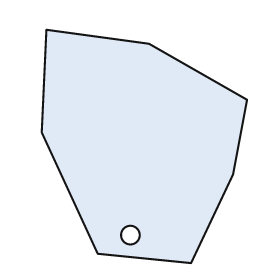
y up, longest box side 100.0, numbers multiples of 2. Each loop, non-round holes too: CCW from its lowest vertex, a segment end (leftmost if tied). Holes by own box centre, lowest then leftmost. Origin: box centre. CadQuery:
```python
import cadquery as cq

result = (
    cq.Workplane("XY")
    .moveTo(20.0, -50.0)
    .lineTo(38.0, -12.0)
    .lineTo(44.0, 20.0)
    .lineTo(2.0, 44.0)
    .lineTo(-42.0, 50.0)
    .lineTo(-44.0, 6.0)
    .lineTo(-20.0, -46.0)
    .close()
    .moveTo(-6.0, -38.0)
    .circle(4.0)
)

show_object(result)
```